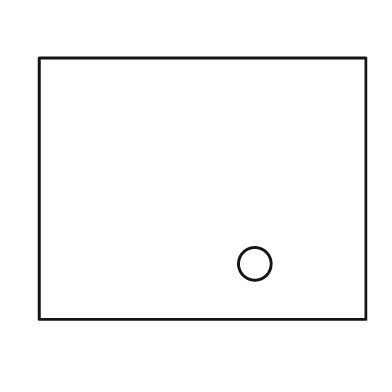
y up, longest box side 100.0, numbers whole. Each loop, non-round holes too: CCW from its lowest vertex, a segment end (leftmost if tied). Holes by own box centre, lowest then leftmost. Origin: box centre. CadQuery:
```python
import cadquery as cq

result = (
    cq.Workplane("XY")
    .moveTo(-50.0, -40.0)
    .lineTo(50.0, -40.0)
    .lineTo(50.0, 40.0)
    .lineTo(-50.0, 40.0)
    .close()
    .moveTo(16.0, -23.0)
    .circle(5.0)
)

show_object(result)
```